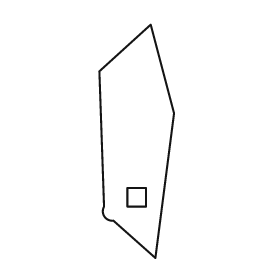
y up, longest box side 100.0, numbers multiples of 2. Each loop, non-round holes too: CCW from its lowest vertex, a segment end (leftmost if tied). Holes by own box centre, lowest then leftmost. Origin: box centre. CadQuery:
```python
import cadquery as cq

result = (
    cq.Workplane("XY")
    .moveTo(8.0, -50.0)
    .lineTo(16.0, 12.0)
    .lineTo(6.0, 50.0)
    .lineTo(-16.0, 30.0)
    .lineTo(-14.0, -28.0)
    .threePointArc((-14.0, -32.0), (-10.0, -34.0))
    .close()
    .moveTo(-4.0, -28.0)
    .lineTo(4.0, -28.0)
    .lineTo(4.0, -20.0)
    .lineTo(-4.0, -20.0)
    .close()
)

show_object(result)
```